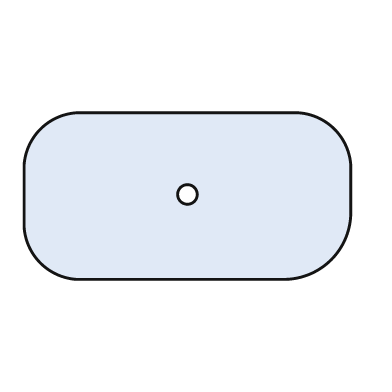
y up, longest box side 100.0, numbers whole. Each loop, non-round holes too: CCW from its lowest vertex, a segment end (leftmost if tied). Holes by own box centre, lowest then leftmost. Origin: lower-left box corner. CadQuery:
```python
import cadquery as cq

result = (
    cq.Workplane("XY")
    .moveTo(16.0, 0.0)
    .lineTo(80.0, 0.0)
    .threePointArc((94.0, 6.0), (100.0, 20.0))
    .lineTo(100.0, 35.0)
    .threePointArc((95.0, 46.0), (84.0, 51.0))
    .lineTo(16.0, 51.0)
    .threePointArc((5.0, 46.0), (0.0, 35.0))
    .lineTo(0.0, 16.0)
    .threePointArc((5.0, 5.0), (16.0, 0.0))
    .close()
    .moveTo(50.0, 26.0)
    .circle(3.0)
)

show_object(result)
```